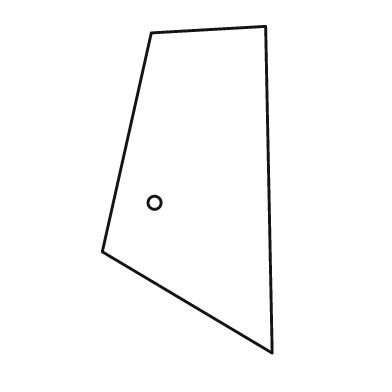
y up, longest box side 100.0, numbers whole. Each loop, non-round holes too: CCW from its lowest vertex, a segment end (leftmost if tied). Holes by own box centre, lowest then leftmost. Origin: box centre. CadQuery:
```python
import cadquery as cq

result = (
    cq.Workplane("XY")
    .moveTo(26.0, -50.0)
    .lineTo(24.0, 50.0)
    .lineTo(-11.0, 48.0)
    .lineTo(-26.0, -19.0)
    .close()
    .moveTo(-10.0, -4.0)
    .circle(2.0)
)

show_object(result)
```